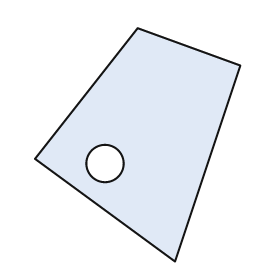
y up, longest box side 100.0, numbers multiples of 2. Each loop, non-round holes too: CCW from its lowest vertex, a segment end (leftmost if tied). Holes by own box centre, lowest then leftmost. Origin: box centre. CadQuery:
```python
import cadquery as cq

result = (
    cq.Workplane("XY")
    .moveTo(16.0, -50.0)
    .lineTo(44.0, 34.0)
    .lineTo(0.0, 50.0)
    .lineTo(-44.0, -6.0)
    .close()
    .moveTo(-14.0, -8.0)
    .circle(8.0)
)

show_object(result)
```